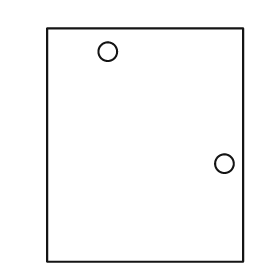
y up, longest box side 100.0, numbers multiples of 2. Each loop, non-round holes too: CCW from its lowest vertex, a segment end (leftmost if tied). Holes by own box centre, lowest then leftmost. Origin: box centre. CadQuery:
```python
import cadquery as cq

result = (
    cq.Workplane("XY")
    .moveTo(-42.0, -50.0)
    .lineTo(42.0, -50.0)
    .lineTo(42.0, 50.0)
    .lineTo(-42.0, 50.0)
    .close()
    .moveTo(34.0, -8.0)
    .circle(4.0)
    .moveTo(-16.0, 40.0)
    .circle(4.0)
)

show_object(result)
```